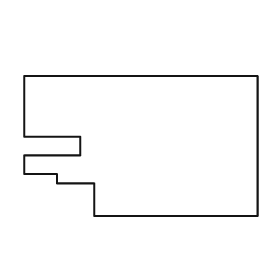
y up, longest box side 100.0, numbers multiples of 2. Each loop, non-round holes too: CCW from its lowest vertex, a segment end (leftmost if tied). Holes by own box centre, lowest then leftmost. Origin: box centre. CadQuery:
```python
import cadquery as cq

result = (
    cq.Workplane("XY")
    .moveTo(-20.0, -30.0)
    .lineTo(50.0, -30.0)
    .lineTo(50.0, 30.0)
    .lineTo(-50.0, 30.0)
    .lineTo(-50.0, 4.0)
    .lineTo(-26.0, 4.0)
    .lineTo(-26.0, -4.0)
    .lineTo(-50.0, -4.0)
    .lineTo(-50.0, -12.0)
    .lineTo(-36.0, -12.0)
    .lineTo(-36.0, -16.0)
    .lineTo(-20.0, -16.0)
    .close()
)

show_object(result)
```